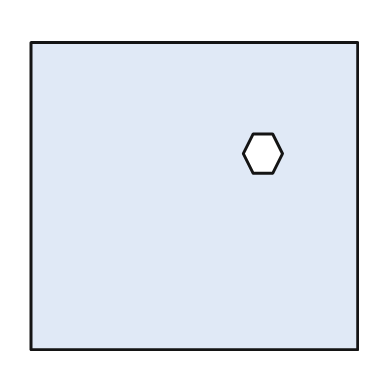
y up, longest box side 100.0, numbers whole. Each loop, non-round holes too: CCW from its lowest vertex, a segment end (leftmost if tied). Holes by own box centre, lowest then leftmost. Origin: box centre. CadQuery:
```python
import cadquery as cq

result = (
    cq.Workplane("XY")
    .moveTo(-50.0, -47.0)
    .lineTo(50.0, -47.0)
    .lineTo(50.0, 47.0)
    .lineTo(-50.0, 47.0)
    .close()
    .moveTo(18.0, 7.0)
    .lineTo(24.0, 7.0)
    .lineTo(27.0, 13.0)
    .lineTo(24.0, 19.0)
    .lineTo(18.0, 19.0)
    .lineTo(15.0, 13.0)
    .close()
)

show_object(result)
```